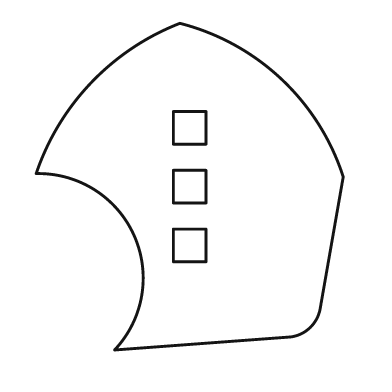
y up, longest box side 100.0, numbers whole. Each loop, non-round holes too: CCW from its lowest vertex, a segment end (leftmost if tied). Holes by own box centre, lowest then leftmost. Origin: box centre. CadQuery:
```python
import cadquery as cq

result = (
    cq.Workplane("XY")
    .moveTo(-23.0, -50.0)
    .lineTo(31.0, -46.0)
    .threePointArc((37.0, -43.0), (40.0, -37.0))
    .lineTo(47.0, 3.0)
    .threePointArc((28.0, 33.0), (-3.0, 50.0))
    .threePointArc((-30.0, 32.0), (-47.0, 4.0))
    .threePointArc((-17.0, -15.0), (-23.0, -50.0))
    .close()
    .moveTo(-5.0, -23.0)
    .lineTo(5.0, -23.0)
    .lineTo(5.0, -13.0)
    .lineTo(-5.0, -13.0)
    .close()
    .moveTo(-5.0, -5.0)
    .lineTo(5.0, -5.0)
    .lineTo(5.0, 5.0)
    .lineTo(-5.0, 5.0)
    .close()
    .moveTo(-5.0, 13.0)
    .lineTo(5.0, 13.0)
    .lineTo(5.0, 23.0)
    .lineTo(-5.0, 23.0)
    .close()
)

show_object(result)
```